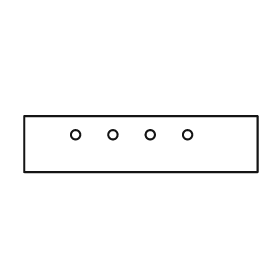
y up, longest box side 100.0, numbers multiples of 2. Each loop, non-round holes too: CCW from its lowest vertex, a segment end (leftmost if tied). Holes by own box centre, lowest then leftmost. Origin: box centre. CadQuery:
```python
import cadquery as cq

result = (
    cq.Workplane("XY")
    .moveTo(-50.0, -12.0)
    .lineTo(50.0, -12.0)
    .lineTo(50.0, 12.0)
    .lineTo(-50.0, 12.0)
    .close()
    .moveTo(-28.0, 4.0)
    .circle(2.0)
    .moveTo(-12.0, 4.0)
    .circle(2.0)
    .moveTo(4.0, 4.0)
    .circle(2.0)
    .moveTo(20.0, 4.0)
    .circle(2.0)
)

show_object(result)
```